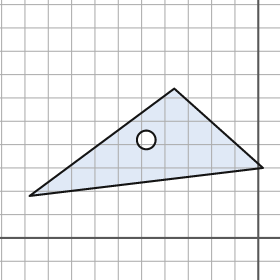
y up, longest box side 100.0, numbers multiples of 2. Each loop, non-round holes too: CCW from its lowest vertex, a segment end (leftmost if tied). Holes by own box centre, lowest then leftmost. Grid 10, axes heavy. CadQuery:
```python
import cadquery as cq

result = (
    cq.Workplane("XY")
    .moveTo(-98.0, 18.0)
    .lineTo(2.0, 30.0)
    .lineTo(-36.0, 64.0)
    .close()
    .moveTo(-48.0, 42.0)
    .circle(4.0)
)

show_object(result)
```